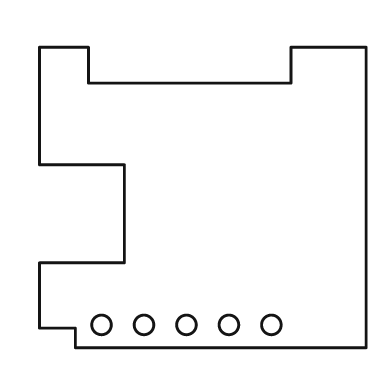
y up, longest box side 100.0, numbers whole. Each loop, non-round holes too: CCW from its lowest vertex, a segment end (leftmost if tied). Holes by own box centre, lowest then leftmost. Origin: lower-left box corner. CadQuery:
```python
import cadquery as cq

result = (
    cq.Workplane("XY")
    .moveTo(11.0, 0.0)
    .lineTo(100.0, 0.0)
    .lineTo(100.0, 92.0)
    .lineTo(77.0, 92.0)
    .lineTo(77.0, 81.0)
    .lineTo(15.0, 81.0)
    .lineTo(15.0, 92.0)
    .lineTo(0.0, 92.0)
    .lineTo(0.0, 56.0)
    .lineTo(26.0, 56.0)
    .lineTo(26.0, 26.0)
    .lineTo(0.0, 26.0)
    .lineTo(0.0, 6.0)
    .lineTo(11.0, 6.0)
    .close()
    .moveTo(19.0, 7.0)
    .circle(3.0)
    .moveTo(32.0, 7.0)
    .circle(3.0)
    .moveTo(45.0, 7.0)
    .circle(3.0)
    .moveTo(58.0, 7.0)
    .circle(3.0)
    .moveTo(71.0, 7.0)
    .circle(3.0)
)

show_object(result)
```